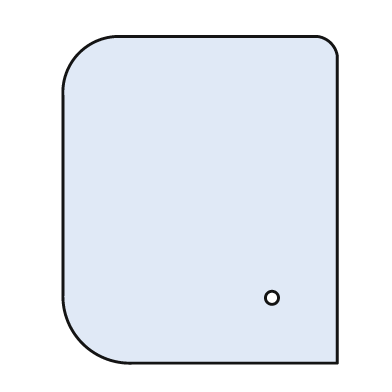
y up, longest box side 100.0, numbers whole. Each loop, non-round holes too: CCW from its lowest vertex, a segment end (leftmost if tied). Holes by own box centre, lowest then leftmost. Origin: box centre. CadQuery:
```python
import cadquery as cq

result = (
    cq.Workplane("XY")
    .moveTo(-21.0, -50.0)
    .lineTo(42.0, -50.0)
    .lineTo(42.0, 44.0)
    .threePointArc((40.0, 48.0), (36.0, 50.0))
    .lineTo(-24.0, 50.0)
    .threePointArc((-37.0, 45.0), (-42.0, 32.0))
    .lineTo(-42.0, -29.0)
    .threePointArc((-36.0, -44.0), (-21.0, -50.0))
    .close()
    .moveTo(22.0, -30.0)
    .circle(2.0)
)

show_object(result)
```